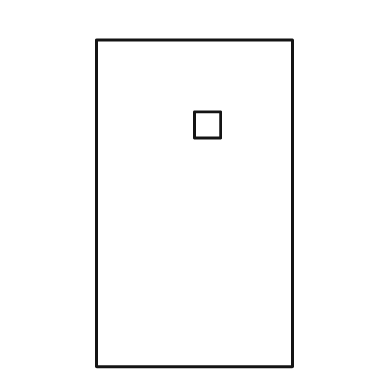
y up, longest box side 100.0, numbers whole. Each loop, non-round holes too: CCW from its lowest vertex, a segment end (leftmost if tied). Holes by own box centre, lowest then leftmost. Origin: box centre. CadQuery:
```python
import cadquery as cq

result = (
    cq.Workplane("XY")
    .moveTo(-30.0, -50.0)
    .lineTo(30.0, -50.0)
    .lineTo(30.0, 50.0)
    .lineTo(-30.0, 50.0)
    .close()
    .moveTo(0.0, 20.0)
    .lineTo(8.0, 20.0)
    .lineTo(8.0, 28.0)
    .lineTo(0.0, 28.0)
    .close()
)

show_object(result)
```